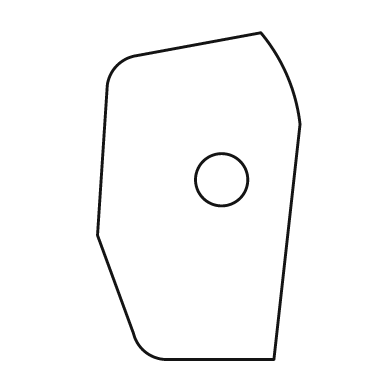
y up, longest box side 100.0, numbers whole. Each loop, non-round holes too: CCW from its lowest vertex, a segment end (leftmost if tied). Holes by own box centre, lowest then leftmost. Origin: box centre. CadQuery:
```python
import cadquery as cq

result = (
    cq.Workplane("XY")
    .moveTo(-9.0, -50.0)
    .lineTo(23.0, -50.0)
    .lineTo(31.0, 22.0)
    .threePointArc((27.0, 37.0), (19.0, 50.0))
    .lineTo(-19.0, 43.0)
    .threePointArc((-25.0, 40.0), (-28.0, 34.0))
    .lineTo(-31.0, -12.0)
    .lineTo(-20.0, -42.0)
    .threePointArc((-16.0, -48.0), (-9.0, -50.0))
    .close()
    .moveTo(7.0, 5.0)
    .circle(8.0)
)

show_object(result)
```